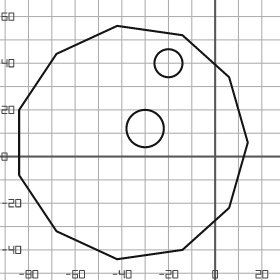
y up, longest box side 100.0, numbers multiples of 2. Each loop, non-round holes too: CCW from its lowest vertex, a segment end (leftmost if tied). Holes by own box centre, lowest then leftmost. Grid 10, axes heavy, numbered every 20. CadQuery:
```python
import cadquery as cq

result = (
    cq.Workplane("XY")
    .moveTo(-42.0, -44.0)
    .lineTo(-14.0, -40.0)
    .lineTo(6.0, -22.0)
    .lineTo(14.0, 6.0)
    .lineTo(6.0, 34.0)
    .lineTo(-14.0, 52.0)
    .lineTo(-42.0, 56.0)
    .lineTo(-68.0, 44.0)
    .lineTo(-84.0, 20.0)
    .lineTo(-84.0, -8.0)
    .lineTo(-68.0, -32.0)
    .close()
    .moveTo(-30.0, 12.0)
    .circle(8.0)
    .moveTo(-20.0, 40.0)
    .circle(6.0)
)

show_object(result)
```